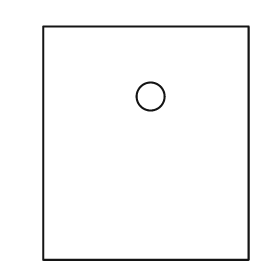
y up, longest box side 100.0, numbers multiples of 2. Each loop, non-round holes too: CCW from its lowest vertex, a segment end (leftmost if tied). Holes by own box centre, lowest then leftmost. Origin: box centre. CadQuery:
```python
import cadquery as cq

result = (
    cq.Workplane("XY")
    .moveTo(-44.0, -50.0)
    .lineTo(44.0, -50.0)
    .lineTo(44.0, 50.0)
    .lineTo(-44.0, 50.0)
    .close()
    .moveTo(2.0, 20.0)
    .circle(6.0)
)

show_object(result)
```